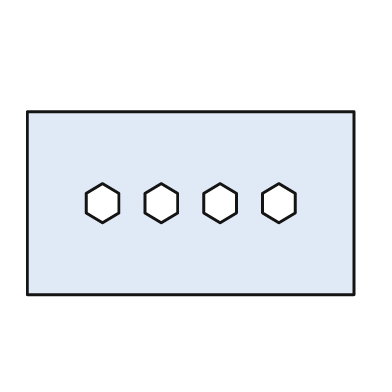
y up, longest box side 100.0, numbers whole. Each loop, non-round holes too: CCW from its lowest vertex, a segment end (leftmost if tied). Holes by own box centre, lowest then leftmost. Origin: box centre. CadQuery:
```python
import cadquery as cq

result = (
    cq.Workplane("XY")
    .moveTo(-50.0, -28.0)
    .lineTo(50.0, -28.0)
    .lineTo(50.0, 28.0)
    .lineTo(-50.0, 28.0)
    .close()
    .moveTo(-27.0, -6.0)
    .lineTo(-22.0, -3.0)
    .lineTo(-22.0, 3.0)
    .lineTo(-27.0, 6.0)
    .lineTo(-32.0, 3.0)
    .lineTo(-32.0, -3.0)
    .close()
    .moveTo(-9.0, -6.0)
    .lineTo(-4.0, -3.0)
    .lineTo(-4.0, 3.0)
    .lineTo(-9.0, 6.0)
    .lineTo(-14.0, 3.0)
    .lineTo(-14.0, -3.0)
    .close()
    .moveTo(9.0, -6.0)
    .lineTo(14.0, -3.0)
    .lineTo(14.0, 3.0)
    .lineTo(9.0, 6.0)
    .lineTo(4.0, 3.0)
    .lineTo(4.0, -3.0)
    .close()
    .moveTo(27.0, -6.0)
    .lineTo(32.0, -3.0)
    .lineTo(32.0, 3.0)
    .lineTo(27.0, 6.0)
    .lineTo(22.0, 3.0)
    .lineTo(22.0, -3.0)
    .close()
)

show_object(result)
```